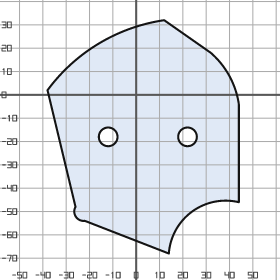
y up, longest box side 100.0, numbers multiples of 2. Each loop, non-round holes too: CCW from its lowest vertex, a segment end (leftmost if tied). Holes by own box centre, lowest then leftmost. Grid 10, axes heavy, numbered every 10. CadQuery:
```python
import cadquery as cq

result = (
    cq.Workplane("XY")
    .moveTo(14.0, -68.0)
    .threePointArc((24.0, -50.0), (44.0, -46.0))
    .lineTo(44.0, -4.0)
    .threePointArc((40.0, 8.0), (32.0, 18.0))
    .lineTo(12.0, 32.0)
    .threePointArc((-16.0, 22.0), (-38.0, 2.0))
    .lineTo(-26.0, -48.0)
    .threePointArc((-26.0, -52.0), (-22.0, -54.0))
    .close()
    .moveTo(-12.0, -18.0)
    .circle(4.0)
    .moveTo(22.0, -18.0)
    .circle(4.0)
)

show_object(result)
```